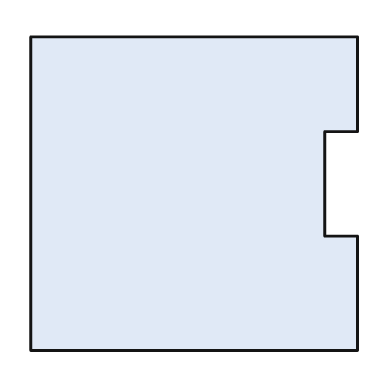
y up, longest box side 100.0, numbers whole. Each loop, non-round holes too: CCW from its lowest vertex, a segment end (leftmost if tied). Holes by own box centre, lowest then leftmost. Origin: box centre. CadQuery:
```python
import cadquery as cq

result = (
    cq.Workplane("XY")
    .moveTo(-50.0, -48.0)
    .lineTo(50.0, -48.0)
    .lineTo(50.0, -13.0)
    .lineTo(40.0, -13.0)
    .lineTo(40.0, 19.0)
    .lineTo(50.0, 19.0)
    .lineTo(50.0, 48.0)
    .lineTo(-50.0, 48.0)
    .close()
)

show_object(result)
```